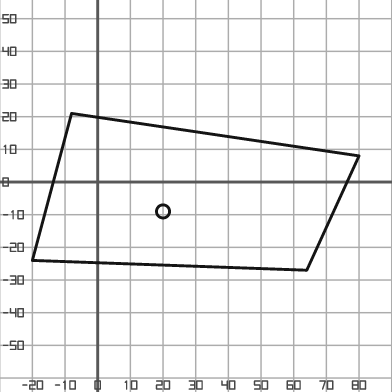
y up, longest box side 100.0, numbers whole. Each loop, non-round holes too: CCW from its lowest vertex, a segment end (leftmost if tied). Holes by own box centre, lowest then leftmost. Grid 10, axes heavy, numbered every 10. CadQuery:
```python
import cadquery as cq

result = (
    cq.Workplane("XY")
    .moveTo(64.0, -27.0)
    .lineTo(80.0, 8.0)
    .lineTo(-8.0, 21.0)
    .lineTo(-20.0, -24.0)
    .close()
    .moveTo(20.0, -9.0)
    .circle(2.0)
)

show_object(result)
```